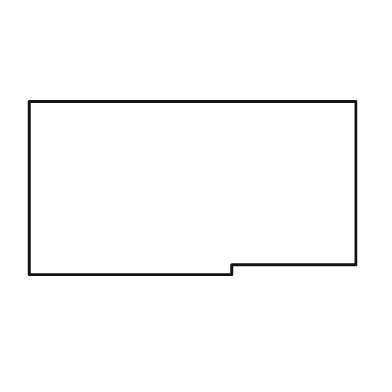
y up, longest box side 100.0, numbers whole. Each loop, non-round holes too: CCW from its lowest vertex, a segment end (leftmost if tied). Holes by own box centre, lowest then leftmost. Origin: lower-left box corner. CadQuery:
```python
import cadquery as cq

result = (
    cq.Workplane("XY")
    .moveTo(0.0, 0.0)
    .lineTo(62.0, 0.0)
    .lineTo(62.0, 3.0)
    .lineTo(100.0, 3.0)
    .lineTo(100.0, 53.0)
    .lineTo(0.0, 53.0)
    .close()
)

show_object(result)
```